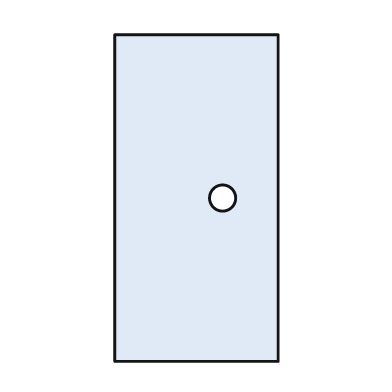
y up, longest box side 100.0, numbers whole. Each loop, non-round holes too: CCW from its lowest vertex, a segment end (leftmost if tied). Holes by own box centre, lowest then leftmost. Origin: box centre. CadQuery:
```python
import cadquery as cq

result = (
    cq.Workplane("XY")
    .moveTo(-25.0, -50.0)
    .lineTo(25.0, -50.0)
    .lineTo(25.0, 50.0)
    .lineTo(-25.0, 50.0)
    .close()
    .moveTo(8.0, 0.0)
    .circle(4.0)
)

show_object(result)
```